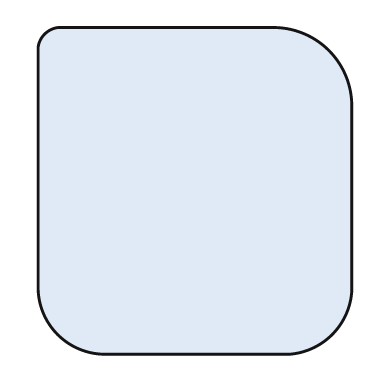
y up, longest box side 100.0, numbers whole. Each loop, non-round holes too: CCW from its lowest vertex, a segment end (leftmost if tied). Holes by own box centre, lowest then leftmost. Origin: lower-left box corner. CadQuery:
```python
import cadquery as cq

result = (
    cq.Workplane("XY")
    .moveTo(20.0, 0.0)
    .lineTo(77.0, 0.0)
    .threePointArc((90.0, 6.0), (96.0, 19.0))
    .lineTo(96.0, 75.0)
    .threePointArc((89.0, 93.0), (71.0, 100.0))
    .lineTo(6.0, 100.0)
    .threePointArc((2.0, 98.0), (0.0, 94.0))
    .lineTo(0.0, 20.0)
    .threePointArc((6.0, 6.0), (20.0, 0.0))
    .close()
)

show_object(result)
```